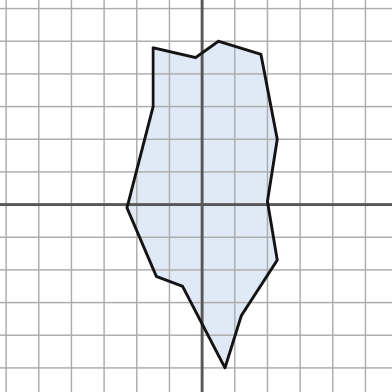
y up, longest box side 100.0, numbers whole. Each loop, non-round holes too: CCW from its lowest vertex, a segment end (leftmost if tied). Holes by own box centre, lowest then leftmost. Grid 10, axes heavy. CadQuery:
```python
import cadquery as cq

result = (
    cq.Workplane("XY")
    .moveTo(7.0, -50.0)
    .lineTo(12.0, -34.0)
    .lineTo(23.0, -17.0)
    .lineTo(20.0, 1.0)
    .lineTo(23.0, 20.0)
    .lineTo(18.0, 46.0)
    .lineTo(5.0, 50.0)
    .lineTo(-2.0, 45.0)
    .lineTo(-15.0, 48.0)
    .lineTo(-15.0, 30.0)
    .lineTo(-23.0, -1.0)
    .lineTo(-14.0, -22.0)
    .lineTo(-6.0, -25.0)
    .close()
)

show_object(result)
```